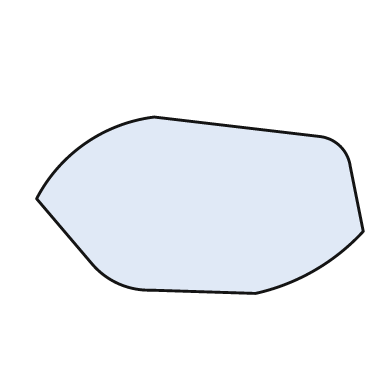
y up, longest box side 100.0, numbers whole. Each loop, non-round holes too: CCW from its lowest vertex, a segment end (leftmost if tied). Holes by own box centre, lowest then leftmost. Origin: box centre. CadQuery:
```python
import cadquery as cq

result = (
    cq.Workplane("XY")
    .moveTo(17.0, -27.0)
    .threePointArc((35.0, -20.0), (50.0, -8.0))
    .lineTo(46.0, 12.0)
    .threePointArc((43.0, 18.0), (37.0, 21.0))
    .lineTo(-14.0, 27.0)
    .threePointArc((-35.0, 19.0), (-50.0, 2.0))
    .lineTo(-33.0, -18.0)
    .threePointArc((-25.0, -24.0), (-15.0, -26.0))
    .close()
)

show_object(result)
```